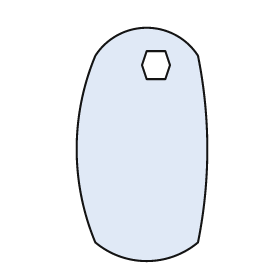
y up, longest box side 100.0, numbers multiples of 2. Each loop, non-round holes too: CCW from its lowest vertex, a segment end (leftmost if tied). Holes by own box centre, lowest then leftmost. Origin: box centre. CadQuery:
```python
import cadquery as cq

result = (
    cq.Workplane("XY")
    .moveTo(-20.0, -42.0)
    .threePointArc((2.0, -50.0), (24.0, -42.0))
    .threePointArc((28.0, -2.0), (24.0, 38.0))
    .threePointArc((2.0, 50.0), (-20.0, 38.0))
    .threePointArc((-28.0, -2.0), (-20.0, -42.0))
    .close()
    .moveTo(2.0, 28.0)
    .lineTo(10.0, 28.0)
    .lineTo(12.0, 34.0)
    .lineTo(10.0, 40.0)
    .lineTo(2.0, 40.0)
    .lineTo(0.0, 34.0)
    .close()
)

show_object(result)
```